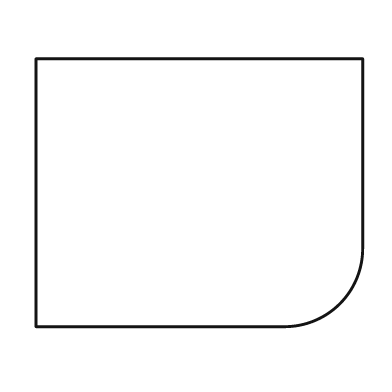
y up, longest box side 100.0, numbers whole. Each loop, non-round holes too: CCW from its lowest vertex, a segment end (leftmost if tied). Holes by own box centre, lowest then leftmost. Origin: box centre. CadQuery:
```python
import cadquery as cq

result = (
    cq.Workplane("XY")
    .moveTo(-50.0, -41.0)
    .lineTo(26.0, -41.0)
    .threePointArc((43.0, -34.0), (50.0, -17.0))
    .lineTo(50.0, 41.0)
    .lineTo(-50.0, 41.0)
    .close()
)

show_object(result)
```